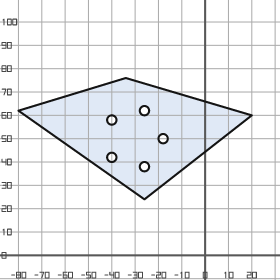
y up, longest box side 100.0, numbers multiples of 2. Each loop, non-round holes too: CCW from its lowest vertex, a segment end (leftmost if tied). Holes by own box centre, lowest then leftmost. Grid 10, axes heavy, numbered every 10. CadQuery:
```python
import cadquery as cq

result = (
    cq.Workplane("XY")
    .moveTo(-26.0, 24.0)
    .lineTo(20.0, 60.0)
    .lineTo(-34.0, 76.0)
    .lineTo(-80.0, 62.0)
    .close()
    .moveTo(-26.0, 38.0)
    .circle(2.0)
    .moveTo(-40.0, 42.0)
    .circle(2.0)
    .moveTo(-18.0, 50.0)
    .circle(2.0)
    .moveTo(-40.0, 58.0)
    .circle(2.0)
    .moveTo(-26.0, 62.0)
    .circle(2.0)
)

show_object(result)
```